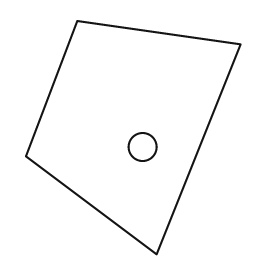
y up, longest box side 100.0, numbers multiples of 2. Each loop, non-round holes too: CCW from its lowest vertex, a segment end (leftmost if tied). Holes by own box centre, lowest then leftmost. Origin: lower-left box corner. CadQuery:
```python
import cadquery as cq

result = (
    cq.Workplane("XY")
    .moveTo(56.0, 0.0)
    .lineTo(92.0, 90.0)
    .lineTo(22.0, 100.0)
    .lineTo(0.0, 42.0)
    .close()
    .moveTo(50.0, 46.0)
    .circle(6.0)
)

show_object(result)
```